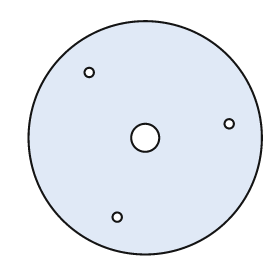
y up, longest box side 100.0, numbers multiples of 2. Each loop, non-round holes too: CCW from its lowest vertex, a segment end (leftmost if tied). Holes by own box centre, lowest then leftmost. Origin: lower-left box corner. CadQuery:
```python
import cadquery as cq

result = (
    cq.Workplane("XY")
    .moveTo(50.0, 50.0)
    .circle(50.0)
    .moveTo(38.0, 16.0)
    .circle(2.0)
    .moveTo(50.0, 50.0)
    .circle(6.0)
    .moveTo(86.0, 56.0)
    .circle(2.0)
    .moveTo(26.0, 78.0)
    .circle(2.0)
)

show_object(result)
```